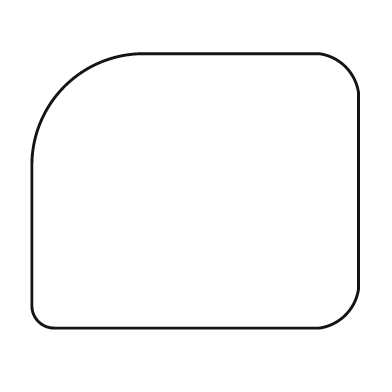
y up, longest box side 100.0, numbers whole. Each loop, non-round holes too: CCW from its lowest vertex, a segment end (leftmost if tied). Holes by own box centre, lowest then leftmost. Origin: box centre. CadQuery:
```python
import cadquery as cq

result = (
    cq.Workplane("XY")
    .moveTo(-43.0, -42.0)
    .lineTo(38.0, -42.0)
    .threePointArc((46.0, -38.0), (50.0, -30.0))
    .lineTo(50.0, 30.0)
    .threePointArc((46.0, 38.0), (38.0, 42.0))
    .lineTo(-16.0, 42.0)
    .threePointArc((-40.0, 32.0), (-50.0, 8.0))
    .lineTo(-50.0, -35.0)
    .threePointArc((-48.0, -40.0), (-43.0, -42.0))
    .close()
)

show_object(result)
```